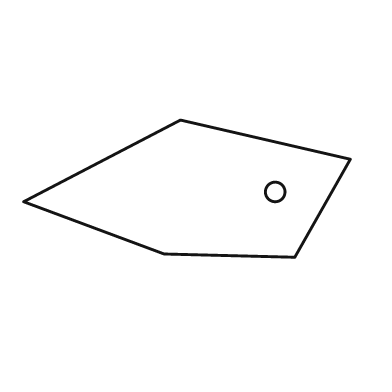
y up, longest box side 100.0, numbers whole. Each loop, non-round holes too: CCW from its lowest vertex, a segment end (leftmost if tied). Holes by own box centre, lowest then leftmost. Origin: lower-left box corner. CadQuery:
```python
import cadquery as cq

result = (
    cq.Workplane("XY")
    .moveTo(83.0, 0.0)
    .lineTo(100.0, 30.0)
    .lineTo(48.0, 42.0)
    .lineTo(0.0, 17.0)
    .lineTo(43.0, 1.0)
    .close()
    .moveTo(77.0, 20.0)
    .circle(3.0)
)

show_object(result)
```